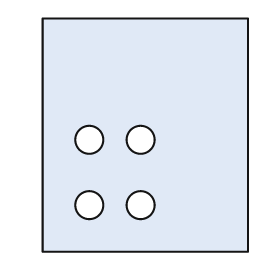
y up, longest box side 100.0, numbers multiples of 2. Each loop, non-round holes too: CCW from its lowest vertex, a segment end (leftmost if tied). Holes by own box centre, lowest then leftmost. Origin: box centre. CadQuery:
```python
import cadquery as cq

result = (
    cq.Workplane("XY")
    .moveTo(-44.0, -50.0)
    .lineTo(44.0, -50.0)
    .lineTo(44.0, 50.0)
    .lineTo(-44.0, 50.0)
    .close()
    .moveTo(-24.0, -30.0)
    .circle(6.0)
    .moveTo(-2.0, -30.0)
    .circle(6.0)
    .moveTo(-24.0, -2.0)
    .circle(6.0)
    .moveTo(-2.0, -2.0)
    .circle(6.0)
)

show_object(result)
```